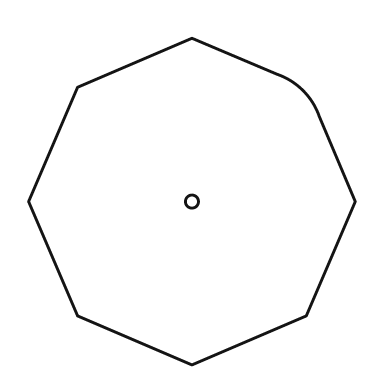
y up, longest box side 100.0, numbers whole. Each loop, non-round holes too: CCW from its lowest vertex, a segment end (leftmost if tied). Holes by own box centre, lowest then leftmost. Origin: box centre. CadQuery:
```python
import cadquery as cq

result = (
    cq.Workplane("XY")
    .moveTo(0.0, -50.0)
    .lineTo(35.0, -35.0)
    .lineTo(50.0, 0.0)
    .lineTo(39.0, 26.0)
    .threePointArc((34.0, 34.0), (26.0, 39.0))
    .lineTo(0.0, 50.0)
    .lineTo(-35.0, 35.0)
    .lineTo(-50.0, 0.0)
    .lineTo(-35.0, -35.0)
    .close()
    .moveTo(0.0, 0.0)
    .circle(2.0)
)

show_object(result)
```